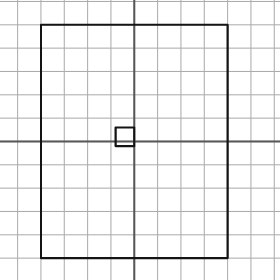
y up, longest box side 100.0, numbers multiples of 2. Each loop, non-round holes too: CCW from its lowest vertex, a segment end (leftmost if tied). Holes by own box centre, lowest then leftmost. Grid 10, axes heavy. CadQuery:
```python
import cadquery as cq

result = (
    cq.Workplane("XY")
    .moveTo(-40.0, -50.0)
    .lineTo(40.0, -50.0)
    .lineTo(40.0, 50.0)
    .lineTo(-40.0, 50.0)
    .close()
    .moveTo(-8.0, -2.0)
    .lineTo(0.0, -2.0)
    .lineTo(0.0, 6.0)
    .lineTo(-8.0, 6.0)
    .close()
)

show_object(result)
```